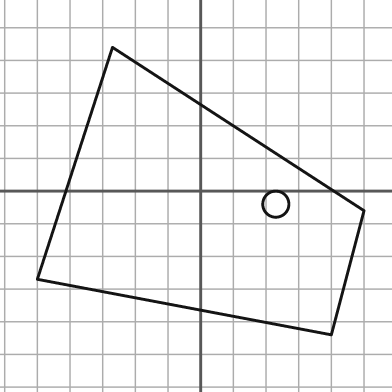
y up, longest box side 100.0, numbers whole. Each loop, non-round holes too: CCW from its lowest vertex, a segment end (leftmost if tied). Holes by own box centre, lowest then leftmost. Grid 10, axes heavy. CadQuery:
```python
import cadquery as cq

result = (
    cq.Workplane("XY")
    .moveTo(40.0, -44.0)
    .lineTo(50.0, -6.0)
    .lineTo(-27.0, 44.0)
    .lineTo(-50.0, -27.0)
    .close()
    .moveTo(23.0, -4.0)
    .circle(4.0)
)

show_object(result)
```